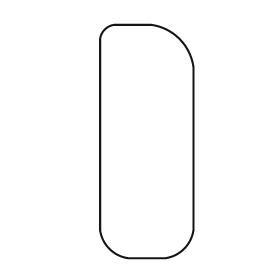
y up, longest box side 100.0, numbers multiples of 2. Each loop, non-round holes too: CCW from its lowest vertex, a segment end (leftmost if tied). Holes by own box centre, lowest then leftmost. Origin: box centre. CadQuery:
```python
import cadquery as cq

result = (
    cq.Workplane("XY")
    .moveTo(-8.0, -50.0)
    .lineTo(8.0, -50.0)
    .threePointArc((16.0, -46.0), (20.0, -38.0))
    .lineTo(20.0, 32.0)
    .threePointArc((14.0, 44.0), (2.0, 50.0))
    .lineTo(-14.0, 50.0)
    .threePointArc((-18.0, 48.0), (-20.0, 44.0))
    .lineTo(-20.0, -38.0)
    .threePointArc((-16.0, -46.0), (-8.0, -50.0))
    .close()
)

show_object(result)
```